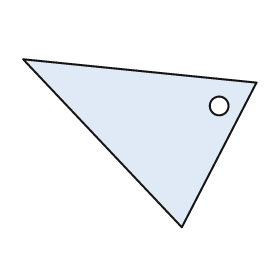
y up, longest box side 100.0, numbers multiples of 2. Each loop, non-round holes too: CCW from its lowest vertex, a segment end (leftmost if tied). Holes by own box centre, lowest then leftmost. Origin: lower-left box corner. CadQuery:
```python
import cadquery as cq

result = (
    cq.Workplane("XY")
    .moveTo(68.0, 0.0)
    .lineTo(100.0, 62.0)
    .lineTo(0.0, 72.0)
    .close()
    .moveTo(84.0, 52.0)
    .circle(4.0)
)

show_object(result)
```